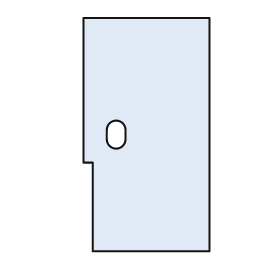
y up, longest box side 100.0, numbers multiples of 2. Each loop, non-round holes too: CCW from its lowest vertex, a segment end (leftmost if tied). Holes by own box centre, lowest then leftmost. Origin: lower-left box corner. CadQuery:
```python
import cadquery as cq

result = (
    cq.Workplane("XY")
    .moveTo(4.0, 0.0)
    .lineTo(54.0, 0.0)
    .lineTo(54.0, 100.0)
    .lineTo(0.0, 100.0)
    .lineTo(0.0, 38.0)
    .lineTo(4.0, 38.0)
    .close()
    .moveTo(10.0, 48.0)
    .threePointArc((14.0, 44.0), (18.0, 48.0))
    .lineTo(18.0, 52.0)
    .threePointArc((14.0, 56.0), (10.0, 52.0))
    .close()
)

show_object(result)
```